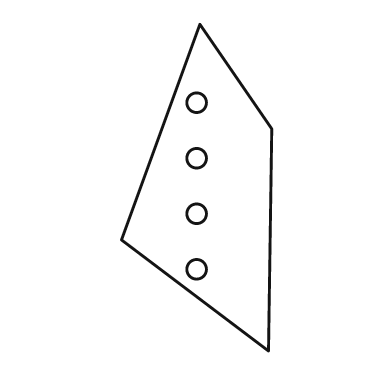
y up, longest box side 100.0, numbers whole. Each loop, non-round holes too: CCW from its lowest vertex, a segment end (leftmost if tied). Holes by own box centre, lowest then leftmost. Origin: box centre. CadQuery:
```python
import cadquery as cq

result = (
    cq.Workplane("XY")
    .moveTo(22.0, -50.0)
    .lineTo(23.0, 18.0)
    .lineTo(1.0, 50.0)
    .lineTo(-23.0, -16.0)
    .close()
    .moveTo(0.0, -25.0)
    .circle(3.0)
    .moveTo(0.0, -8.0)
    .circle(3.0)
    .moveTo(0.0, 9.0)
    .circle(3.0)
    .moveTo(0.0, 26.0)
    .circle(3.0)
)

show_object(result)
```